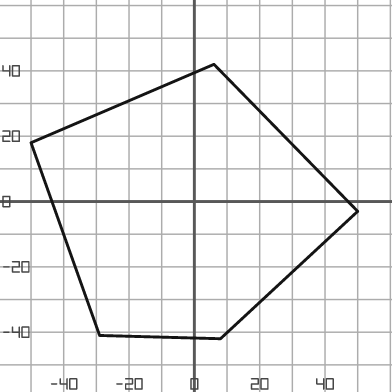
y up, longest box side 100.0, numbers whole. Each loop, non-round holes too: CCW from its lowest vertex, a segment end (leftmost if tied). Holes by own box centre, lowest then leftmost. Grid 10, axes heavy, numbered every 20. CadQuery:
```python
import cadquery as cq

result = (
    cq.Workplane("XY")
    .moveTo(8.0, -42.0)
    .lineTo(50.0, -3.0)
    .lineTo(6.0, 42.0)
    .lineTo(-50.0, 18.0)
    .lineTo(-29.0, -41.0)
    .close()
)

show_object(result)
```